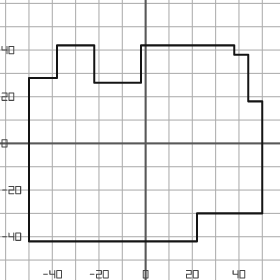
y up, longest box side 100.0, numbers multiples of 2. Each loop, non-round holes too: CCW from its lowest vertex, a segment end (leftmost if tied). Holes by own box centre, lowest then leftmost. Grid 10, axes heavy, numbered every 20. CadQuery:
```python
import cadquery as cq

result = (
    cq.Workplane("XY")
    .moveTo(-50.0, -42.0)
    .lineTo(22.0, -42.0)
    .lineTo(22.0, -30.0)
    .lineTo(50.0, -30.0)
    .lineTo(50.0, 18.0)
    .lineTo(44.0, 18.0)
    .lineTo(44.0, 38.0)
    .lineTo(38.0, 38.0)
    .lineTo(38.0, 42.0)
    .lineTo(-2.0, 42.0)
    .lineTo(-2.0, 26.0)
    .lineTo(-22.0, 26.0)
    .lineTo(-22.0, 42.0)
    .lineTo(-38.0, 42.0)
    .lineTo(-38.0, 28.0)
    .lineTo(-50.0, 28.0)
    .close()
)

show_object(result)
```